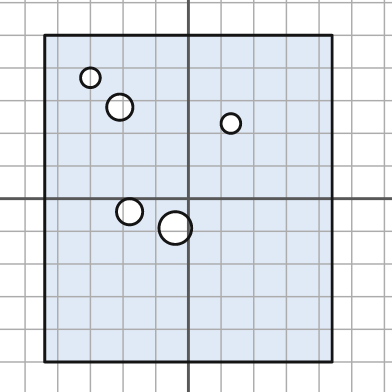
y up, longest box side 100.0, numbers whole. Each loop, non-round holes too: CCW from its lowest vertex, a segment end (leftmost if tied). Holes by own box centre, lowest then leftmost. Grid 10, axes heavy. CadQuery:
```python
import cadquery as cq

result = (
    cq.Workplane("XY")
    .moveTo(-44.0, -50.0)
    .lineTo(44.0, -50.0)
    .lineTo(44.0, 50.0)
    .lineTo(-44.0, 50.0)
    .close()
    .moveTo(-4.0, -9.0)
    .circle(5.0)
    .moveTo(-18.0, -4.0)
    .circle(4.0)
    .moveTo(13.0, 23.0)
    .circle(3.0)
    .moveTo(-21.0, 28.0)
    .circle(4.0)
    .moveTo(-30.0, 37.0)
    .circle(3.0)
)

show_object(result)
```